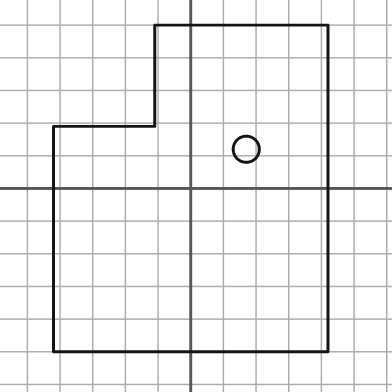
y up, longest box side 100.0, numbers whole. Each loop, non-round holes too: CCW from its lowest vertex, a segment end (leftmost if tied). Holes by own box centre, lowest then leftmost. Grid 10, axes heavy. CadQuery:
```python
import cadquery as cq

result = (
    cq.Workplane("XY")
    .moveTo(-42.0, -50.0)
    .lineTo(42.0, -50.0)
    .lineTo(42.0, 50.0)
    .lineTo(-11.0, 50.0)
    .lineTo(-11.0, 19.0)
    .lineTo(-42.0, 19.0)
    .close()
    .moveTo(17.0, 12.0)
    .circle(4.0)
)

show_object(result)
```